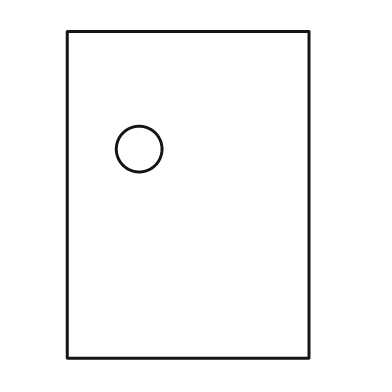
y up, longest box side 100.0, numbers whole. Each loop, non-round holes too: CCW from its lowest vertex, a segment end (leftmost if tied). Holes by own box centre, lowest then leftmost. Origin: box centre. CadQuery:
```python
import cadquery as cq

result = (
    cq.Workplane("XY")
    .moveTo(-37.0, -50.0)
    .lineTo(37.0, -50.0)
    .lineTo(37.0, 50.0)
    .lineTo(-37.0, 50.0)
    .close()
    .moveTo(-15.0, 14.0)
    .circle(7.0)
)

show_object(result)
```